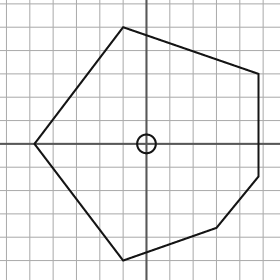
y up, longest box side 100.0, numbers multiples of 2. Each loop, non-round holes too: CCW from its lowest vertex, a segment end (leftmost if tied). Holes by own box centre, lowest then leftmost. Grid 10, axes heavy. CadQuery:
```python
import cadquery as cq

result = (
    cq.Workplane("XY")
    .moveTo(-10.0, -50.0)
    .lineTo(30.0, -36.0)
    .lineTo(48.0, -14.0)
    .lineTo(48.0, 30.0)
    .lineTo(-10.0, 50.0)
    .lineTo(-48.0, 0.0)
    .close()
    .moveTo(0.0, 0.0)
    .circle(4.0)
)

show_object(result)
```